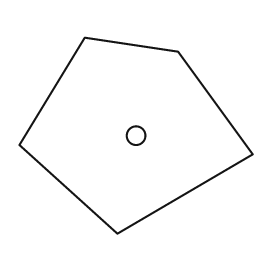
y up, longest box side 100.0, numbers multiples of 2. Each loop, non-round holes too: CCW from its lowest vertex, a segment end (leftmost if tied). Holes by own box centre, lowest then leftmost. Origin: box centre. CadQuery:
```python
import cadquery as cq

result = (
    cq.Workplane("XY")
    .moveTo(-8.0, -42.0)
    .lineTo(50.0, -8.0)
    .lineTo(18.0, 36.0)
    .lineTo(-22.0, 42.0)
    .lineTo(-50.0, -4.0)
    .close()
    .moveTo(0.0, 0.0)
    .circle(4.0)
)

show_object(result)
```